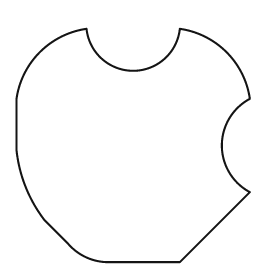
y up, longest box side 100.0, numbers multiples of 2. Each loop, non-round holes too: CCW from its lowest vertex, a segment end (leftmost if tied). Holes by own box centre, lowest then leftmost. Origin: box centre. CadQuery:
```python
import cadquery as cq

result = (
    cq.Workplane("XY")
    .moveTo(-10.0, -50.0)
    .lineTo(20.0, -50.0)
    .lineTo(50.0, -20.0)
    .threePointArc((38.0, 0.0), (50.0, 20.0))
    .threePointArc((40.0, 40.0), (20.0, 50.0))
    .threePointArc((0.0, 32.0), (-20.0, 50.0))
    .threePointArc((-40.0, 40.0), (-50.0, 20.0))
    .lineTo(-50.0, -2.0)
    .threePointArc((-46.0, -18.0), (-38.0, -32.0))
    .lineTo(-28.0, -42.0)
    .threePointArc((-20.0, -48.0), (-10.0, -50.0))
    .close()
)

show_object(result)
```